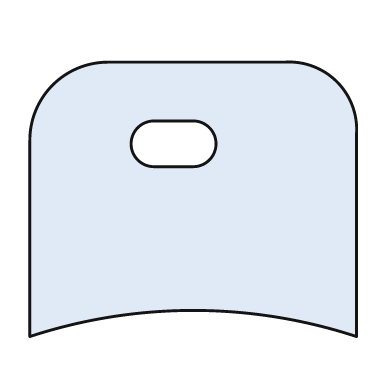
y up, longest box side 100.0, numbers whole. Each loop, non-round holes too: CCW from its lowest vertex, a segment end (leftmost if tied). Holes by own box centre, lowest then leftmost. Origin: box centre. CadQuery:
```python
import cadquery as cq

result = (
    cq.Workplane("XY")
    .moveTo(-50.0, -42.0)
    .threePointArc((0.0, -34.0), (50.0, -42.0))
    .lineTo(50.0, 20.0)
    .threePointArc((44.0, 36.0), (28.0, 42.0))
    .lineTo(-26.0, 42.0)
    .threePointArc((-43.0, 35.0), (-50.0, 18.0))
    .close()
    .moveTo(-12.0, 10.0)
    .lineTo(0.0, 10.0)
    .threePointArc((7.0, 17.0), (0.0, 24.0))
    .lineTo(-12.0, 24.0)
    .threePointArc((-19.0, 17.0), (-12.0, 10.0))
    .close()
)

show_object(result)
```